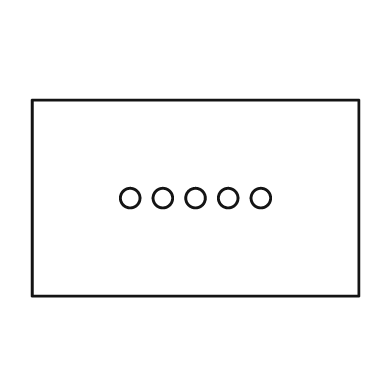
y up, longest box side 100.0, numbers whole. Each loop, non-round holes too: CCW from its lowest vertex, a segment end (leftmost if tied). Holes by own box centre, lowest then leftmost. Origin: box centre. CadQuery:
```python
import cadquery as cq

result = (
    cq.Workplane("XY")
    .moveTo(-50.0, -30.0)
    .lineTo(50.0, -30.0)
    .lineTo(50.0, 30.0)
    .lineTo(-50.0, 30.0)
    .close()
    .moveTo(-20.0, 0.0)
    .circle(3.0)
    .moveTo(-10.0, 0.0)
    .circle(3.0)
    .moveTo(0.0, 0.0)
    .circle(3.0)
    .moveTo(10.0, 0.0)
    .circle(3.0)
    .moveTo(20.0, 0.0)
    .circle(3.0)
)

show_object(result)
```